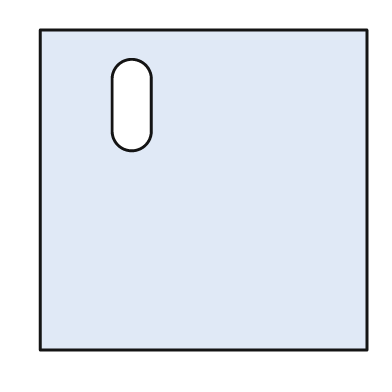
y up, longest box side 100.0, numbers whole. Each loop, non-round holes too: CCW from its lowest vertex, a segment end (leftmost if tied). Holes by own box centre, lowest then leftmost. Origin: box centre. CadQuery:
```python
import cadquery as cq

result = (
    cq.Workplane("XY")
    .moveTo(-50.0, -49.0)
    .lineTo(50.0, -49.0)
    .lineTo(50.0, 49.0)
    .lineTo(-50.0, 49.0)
    .close()
    .moveTo(-28.0, 18.0)
    .threePointArc((-22.0, 12.0), (-16.0, 18.0))
    .lineTo(-16.0, 34.0)
    .threePointArc((-22.0, 40.0), (-28.0, 34.0))
    .close()
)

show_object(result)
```